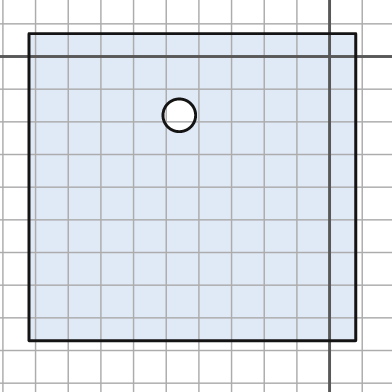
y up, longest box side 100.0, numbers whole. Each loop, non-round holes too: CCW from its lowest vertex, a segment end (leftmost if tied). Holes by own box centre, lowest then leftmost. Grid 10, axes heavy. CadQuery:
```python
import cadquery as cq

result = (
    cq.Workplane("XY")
    .moveTo(-92.0, -87.0)
    .lineTo(8.0, -87.0)
    .lineTo(8.0, 7.0)
    .lineTo(-92.0, 7.0)
    .close()
    .moveTo(-46.0, -18.0)
    .circle(5.0)
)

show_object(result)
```